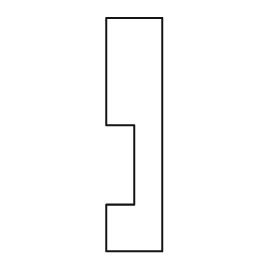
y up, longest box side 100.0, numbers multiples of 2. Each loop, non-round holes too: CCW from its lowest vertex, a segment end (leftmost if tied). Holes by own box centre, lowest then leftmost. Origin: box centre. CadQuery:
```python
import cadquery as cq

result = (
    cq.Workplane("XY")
    .moveTo(-12.0, -50.0)
    .lineTo(12.0, -50.0)
    .lineTo(12.0, 50.0)
    .lineTo(-12.0, 50.0)
    .lineTo(-12.0, 4.0)
    .lineTo(0.0, 4.0)
    .lineTo(0.0, -30.0)
    .lineTo(-12.0, -30.0)
    .close()
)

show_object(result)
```